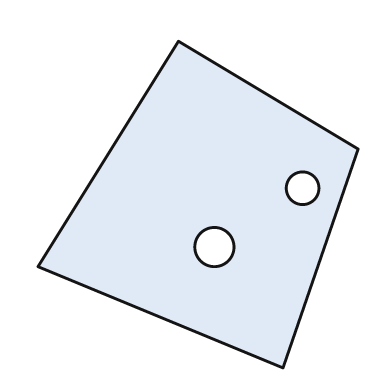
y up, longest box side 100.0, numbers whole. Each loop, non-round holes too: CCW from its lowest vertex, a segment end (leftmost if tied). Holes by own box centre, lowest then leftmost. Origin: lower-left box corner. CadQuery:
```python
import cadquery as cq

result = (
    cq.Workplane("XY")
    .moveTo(75.0, 0.0)
    .lineTo(98.0, 67.0)
    .lineTo(43.0, 100.0)
    .lineTo(0.0, 31.0)
    .close()
    .moveTo(54.0, 37.0)
    .circle(6.0)
    .moveTo(81.0, 55.0)
    .circle(5.0)
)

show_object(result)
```